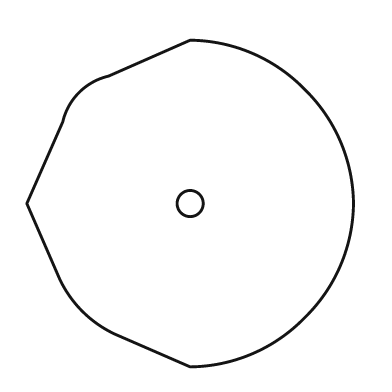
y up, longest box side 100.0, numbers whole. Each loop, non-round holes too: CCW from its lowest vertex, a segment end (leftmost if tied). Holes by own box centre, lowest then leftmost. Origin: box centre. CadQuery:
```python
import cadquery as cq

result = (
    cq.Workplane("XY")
    .moveTo(0.0, -50.0)
    .threePointArc((19.0, -46.0), (35.0, -35.0))
    .threePointArc((46.0, -19.0), (50.0, 0.0))
    .threePointArc((46.0, 19.0), (35.0, 35.0))
    .threePointArc((19.0, 46.0), (0.0, 50.0))
    .lineTo(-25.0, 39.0)
    .threePointArc((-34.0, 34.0), (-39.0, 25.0))
    .lineTo(-50.0, 0.0)
    .lineTo(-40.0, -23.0)
    .threePointArc((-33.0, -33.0), (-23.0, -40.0))
    .close()
    .moveTo(0.0, 0.0)
    .circle(4.0)
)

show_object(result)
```